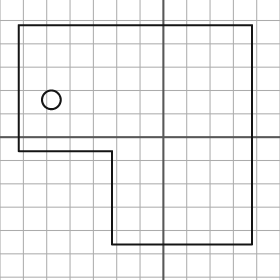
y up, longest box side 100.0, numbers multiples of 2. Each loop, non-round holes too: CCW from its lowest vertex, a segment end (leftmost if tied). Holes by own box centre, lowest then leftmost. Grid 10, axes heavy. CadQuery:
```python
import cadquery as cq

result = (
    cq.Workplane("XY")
    .moveTo(-22.0, -46.0)
    .lineTo(38.0, -46.0)
    .lineTo(38.0, 48.0)
    .lineTo(-62.0, 48.0)
    .lineTo(-62.0, -6.0)
    .lineTo(-22.0, -6.0)
    .close()
    .moveTo(-48.0, 16.0)
    .circle(4.0)
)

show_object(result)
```